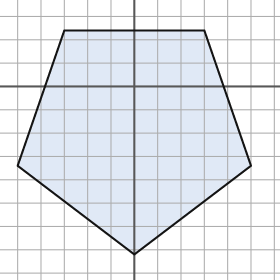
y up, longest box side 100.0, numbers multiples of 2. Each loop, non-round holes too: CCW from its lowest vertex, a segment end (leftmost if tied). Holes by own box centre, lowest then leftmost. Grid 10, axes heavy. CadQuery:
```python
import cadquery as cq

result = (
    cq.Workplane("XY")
    .moveTo(0.0, -72.0)
    .lineTo(50.0, -34.0)
    .lineTo(30.0, 24.0)
    .lineTo(-30.0, 24.0)
    .lineTo(-50.0, -34.0)
    .close()
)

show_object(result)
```